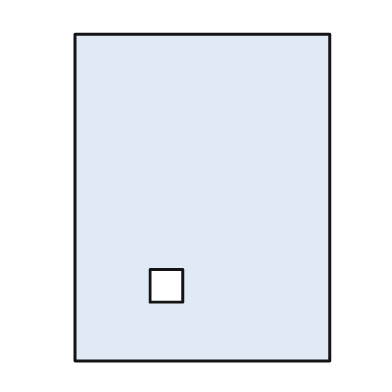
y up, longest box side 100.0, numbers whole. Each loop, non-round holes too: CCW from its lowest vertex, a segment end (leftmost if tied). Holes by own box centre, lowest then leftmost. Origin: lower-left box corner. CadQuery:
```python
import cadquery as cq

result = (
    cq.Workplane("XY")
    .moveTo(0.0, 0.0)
    .lineTo(78.0, 0.0)
    .lineTo(78.0, 100.0)
    .lineTo(0.0, 100.0)
    .close()
    .moveTo(23.0, 18.0)
    .lineTo(33.0, 18.0)
    .lineTo(33.0, 28.0)
    .lineTo(23.0, 28.0)
    .close()
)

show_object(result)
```